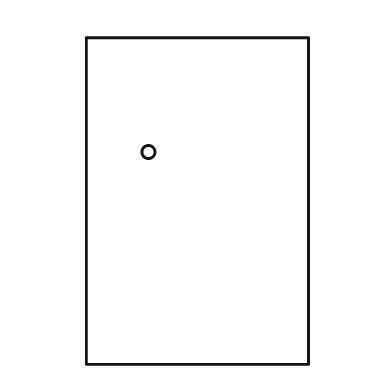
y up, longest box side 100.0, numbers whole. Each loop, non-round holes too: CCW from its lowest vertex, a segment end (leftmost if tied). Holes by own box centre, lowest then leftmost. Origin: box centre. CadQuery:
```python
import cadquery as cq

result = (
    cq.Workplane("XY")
    .moveTo(-34.0, -50.0)
    .lineTo(34.0, -50.0)
    .lineTo(34.0, 50.0)
    .lineTo(-34.0, 50.0)
    .close()
    .moveTo(-15.0, 15.0)
    .circle(2.0)
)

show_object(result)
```